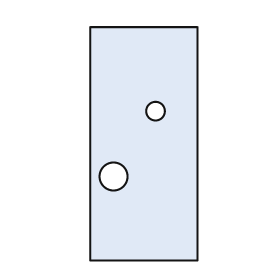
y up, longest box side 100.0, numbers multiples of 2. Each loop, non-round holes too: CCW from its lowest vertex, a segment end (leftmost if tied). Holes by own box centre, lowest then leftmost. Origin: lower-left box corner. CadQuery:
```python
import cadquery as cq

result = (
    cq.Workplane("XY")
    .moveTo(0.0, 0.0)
    .lineTo(46.0, 0.0)
    .lineTo(46.0, 100.0)
    .lineTo(0.0, 100.0)
    .close()
    .moveTo(10.0, 36.0)
    .circle(6.0)
    .moveTo(28.0, 64.0)
    .circle(4.0)
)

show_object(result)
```